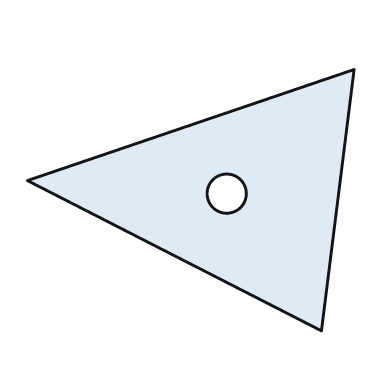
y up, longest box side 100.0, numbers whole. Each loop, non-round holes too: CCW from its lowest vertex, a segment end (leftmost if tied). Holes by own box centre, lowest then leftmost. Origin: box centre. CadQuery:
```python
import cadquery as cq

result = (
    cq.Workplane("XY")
    .moveTo(40.0, -40.0)
    .lineTo(50.0, 40.0)
    .lineTo(-50.0, 6.0)
    .close()
    .moveTo(11.0, 2.0)
    .circle(6.0)
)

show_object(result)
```